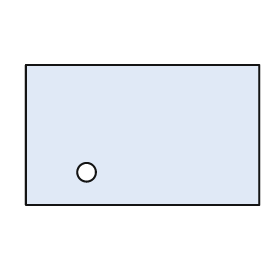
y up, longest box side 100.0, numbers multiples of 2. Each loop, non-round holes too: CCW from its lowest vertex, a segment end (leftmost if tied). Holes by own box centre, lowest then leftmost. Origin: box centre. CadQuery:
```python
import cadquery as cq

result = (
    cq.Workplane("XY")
    .moveTo(-50.0, -30.0)
    .lineTo(50.0, -30.0)
    .lineTo(50.0, 30.0)
    .lineTo(-50.0, 30.0)
    .close()
    .moveTo(-24.0, -16.0)
    .circle(4.0)
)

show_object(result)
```